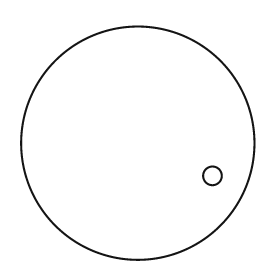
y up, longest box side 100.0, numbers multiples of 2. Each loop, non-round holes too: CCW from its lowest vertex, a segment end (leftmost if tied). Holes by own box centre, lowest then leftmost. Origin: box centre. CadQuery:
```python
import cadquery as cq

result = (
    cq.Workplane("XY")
    .moveTo(0.0, 0.0)
    .circle(50.0)
    .moveTo(32.0, -14.0)
    .circle(4.0)
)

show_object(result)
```